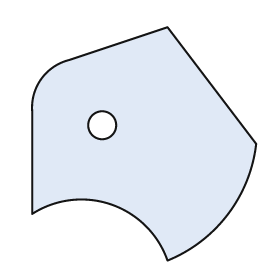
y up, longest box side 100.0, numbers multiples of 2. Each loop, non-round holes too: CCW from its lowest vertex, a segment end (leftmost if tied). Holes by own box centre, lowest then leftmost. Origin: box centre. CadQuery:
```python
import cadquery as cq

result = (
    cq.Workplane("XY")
    .moveTo(10.0, -50.0)
    .threePointArc((36.0, -30.0), (48.0, 0.0))
    .lineTo(10.0, 50.0)
    .lineTo(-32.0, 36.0)
    .threePointArc((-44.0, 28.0), (-48.0, 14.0))
    .lineTo(-48.0, -30.0)
    .threePointArc((-14.0, -26.0), (10.0, -50.0))
    .close()
    .moveTo(-18.0, 8.0)
    .circle(6.0)
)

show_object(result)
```